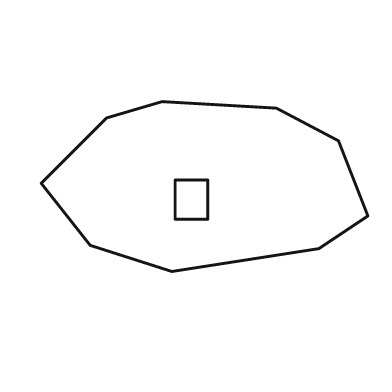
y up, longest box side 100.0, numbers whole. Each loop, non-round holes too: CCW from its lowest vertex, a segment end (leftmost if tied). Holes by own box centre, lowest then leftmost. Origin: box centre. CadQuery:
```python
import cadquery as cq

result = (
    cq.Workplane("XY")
    .moveTo(-10.0, -26.0)
    .lineTo(35.0, -19.0)
    .lineTo(50.0, -9.0)
    .lineTo(41.0, 14.0)
    .lineTo(22.0, 24.0)
    .lineTo(-13.0, 26.0)
    .lineTo(-30.0, 21.0)
    .lineTo(-50.0, 1.0)
    .lineTo(-35.0, -18.0)
    .close()
    .moveTo(-9.0, -10.0)
    .lineTo(1.0, -10.0)
    .lineTo(1.0, 2.0)
    .lineTo(-9.0, 2.0)
    .close()
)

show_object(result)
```